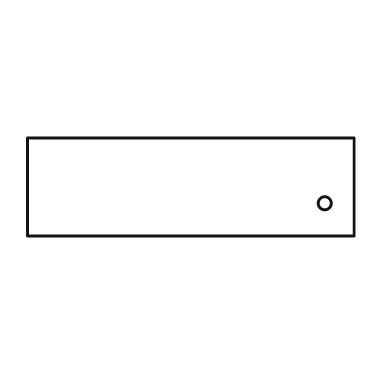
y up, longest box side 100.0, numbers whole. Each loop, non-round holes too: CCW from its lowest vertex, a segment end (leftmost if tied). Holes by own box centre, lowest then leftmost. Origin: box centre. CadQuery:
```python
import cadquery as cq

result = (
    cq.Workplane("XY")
    .moveTo(-50.0, -15.0)
    .lineTo(50.0, -15.0)
    .lineTo(50.0, 15.0)
    .lineTo(-50.0, 15.0)
    .close()
    .moveTo(41.0, -5.0)
    .circle(2.0)
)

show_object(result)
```